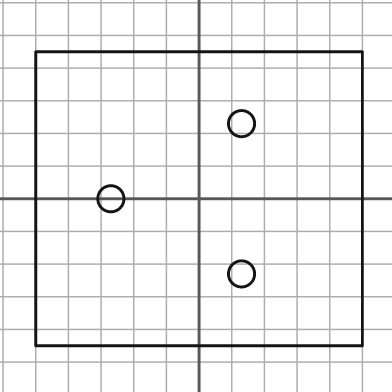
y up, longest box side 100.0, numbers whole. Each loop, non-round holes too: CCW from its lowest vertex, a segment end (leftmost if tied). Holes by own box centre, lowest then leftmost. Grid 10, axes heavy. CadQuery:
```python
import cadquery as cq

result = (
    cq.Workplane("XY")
    .moveTo(-50.0, -45.0)
    .lineTo(50.0, -45.0)
    .lineTo(50.0, 45.0)
    .lineTo(-50.0, 45.0)
    .close()
    .moveTo(13.0, -23.0)
    .circle(4.0)
    .moveTo(-27.0, 0.0)
    .circle(4.0)
    .moveTo(13.0, 23.0)
    .circle(4.0)
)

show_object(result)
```